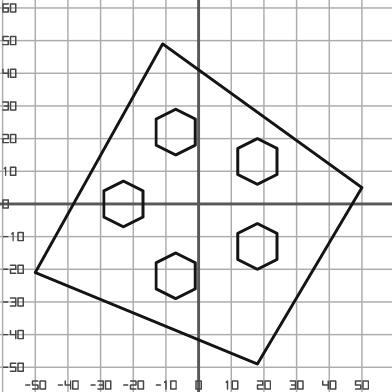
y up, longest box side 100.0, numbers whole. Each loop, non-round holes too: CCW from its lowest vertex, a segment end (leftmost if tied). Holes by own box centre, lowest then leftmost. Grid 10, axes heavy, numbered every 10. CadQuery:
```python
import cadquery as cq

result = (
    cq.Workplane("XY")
    .moveTo(18.0, -49.0)
    .lineTo(50.0, 5.0)
    .lineTo(-11.0, 49.0)
    .lineTo(-50.0, -21.0)
    .close()
    .moveTo(-7.0, -29.0)
    .lineTo(-1.0, -26.0)
    .lineTo(-1.0, -18.0)
    .lineTo(-7.0, -15.0)
    .lineTo(-13.0, -18.0)
    .lineTo(-13.0, -26.0)
    .close()
    .moveTo(18.0, -20.0)
    .lineTo(24.0, -17.0)
    .lineTo(24.0, -9.0)
    .lineTo(18.0, -6.0)
    .lineTo(12.0, -9.0)
    .lineTo(12.0, -17.0)
    .close()
    .moveTo(-23.0, -7.0)
    .lineTo(-17.0, -4.0)
    .lineTo(-17.0, 4.0)
    .lineTo(-23.0, 7.0)
    .lineTo(-29.0, 4.0)
    .lineTo(-29.0, -4.0)
    .close()
    .moveTo(18.0, 6.0)
    .lineTo(24.0, 9.0)
    .lineTo(24.0, 17.0)
    .lineTo(18.0, 20.0)
    .lineTo(12.0, 17.0)
    .lineTo(12.0, 9.0)
    .close()
    .moveTo(-7.0, 15.0)
    .lineTo(-1.0, 18.0)
    .lineTo(-1.0, 26.0)
    .lineTo(-7.0, 29.0)
    .lineTo(-13.0, 26.0)
    .lineTo(-13.0, 18.0)
    .close()
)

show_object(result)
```